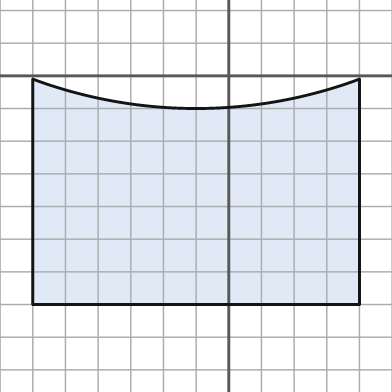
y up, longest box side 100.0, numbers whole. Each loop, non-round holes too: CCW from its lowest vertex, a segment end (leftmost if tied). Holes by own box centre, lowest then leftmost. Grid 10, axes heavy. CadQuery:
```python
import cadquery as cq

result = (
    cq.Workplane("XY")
    .moveTo(-60.0, -70.0)
    .lineTo(40.0, -70.0)
    .lineTo(40.0, -1.0)
    .threePointArc((-10.0, -10.0), (-60.0, -1.0))
    .close()
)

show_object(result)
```